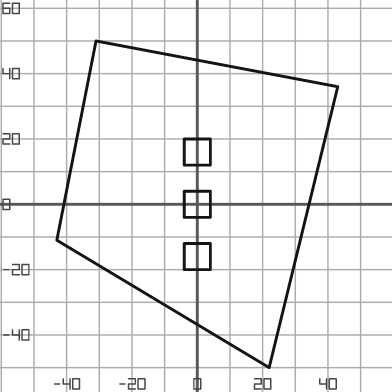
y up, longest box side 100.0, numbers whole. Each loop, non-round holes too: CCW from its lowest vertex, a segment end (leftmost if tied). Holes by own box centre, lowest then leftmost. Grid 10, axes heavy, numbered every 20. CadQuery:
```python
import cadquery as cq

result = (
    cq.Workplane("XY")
    .moveTo(22.0, -50.0)
    .lineTo(43.0, 36.0)
    .lineTo(-31.0, 50.0)
    .lineTo(-43.0, -11.0)
    .close()
    .moveTo(-4.0, -20.0)
    .lineTo(4.0, -20.0)
    .lineTo(4.0, -12.0)
    .lineTo(-4.0, -12.0)
    .close()
    .moveTo(-4.0, -4.0)
    .lineTo(4.0, -4.0)
    .lineTo(4.0, 4.0)
    .lineTo(-4.0, 4.0)
    .close()
    .moveTo(-4.0, 12.0)
    .lineTo(4.0, 12.0)
    .lineTo(4.0, 20.0)
    .lineTo(-4.0, 20.0)
    .close()
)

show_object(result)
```